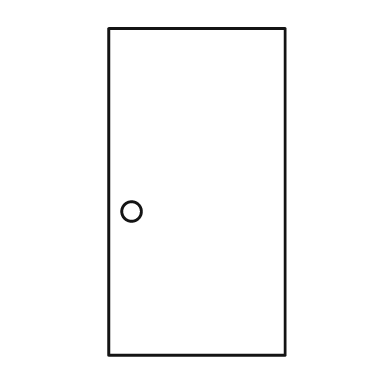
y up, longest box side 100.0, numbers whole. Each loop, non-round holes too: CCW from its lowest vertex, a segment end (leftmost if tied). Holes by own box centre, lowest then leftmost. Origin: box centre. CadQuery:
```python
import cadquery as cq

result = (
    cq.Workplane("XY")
    .moveTo(-27.0, -50.0)
    .lineTo(27.0, -50.0)
    .lineTo(27.0, 50.0)
    .lineTo(-27.0, 50.0)
    .close()
    .moveTo(-20.0, -6.0)
    .circle(3.0)
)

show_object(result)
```